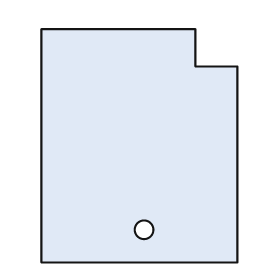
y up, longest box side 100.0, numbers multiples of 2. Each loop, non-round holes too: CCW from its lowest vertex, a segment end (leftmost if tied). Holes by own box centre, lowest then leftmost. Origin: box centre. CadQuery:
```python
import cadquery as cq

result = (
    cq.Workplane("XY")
    .moveTo(-42.0, -50.0)
    .lineTo(42.0, -50.0)
    .lineTo(42.0, 34.0)
    .lineTo(24.0, 34.0)
    .lineTo(24.0, 50.0)
    .lineTo(-42.0, 50.0)
    .close()
    .moveTo(2.0, -36.0)
    .circle(4.0)
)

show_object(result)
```